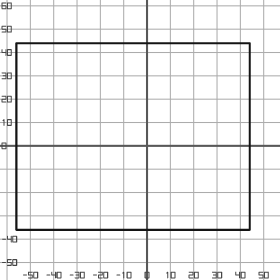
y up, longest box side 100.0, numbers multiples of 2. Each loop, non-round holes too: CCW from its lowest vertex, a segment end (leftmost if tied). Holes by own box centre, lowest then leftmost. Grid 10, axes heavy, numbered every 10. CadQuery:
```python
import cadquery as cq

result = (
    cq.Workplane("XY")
    .moveTo(-56.0, -36.0)
    .lineTo(44.0, -36.0)
    .lineTo(44.0, 44.0)
    .lineTo(-56.0, 44.0)
    .close()
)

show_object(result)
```